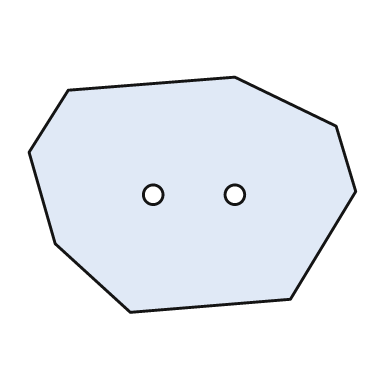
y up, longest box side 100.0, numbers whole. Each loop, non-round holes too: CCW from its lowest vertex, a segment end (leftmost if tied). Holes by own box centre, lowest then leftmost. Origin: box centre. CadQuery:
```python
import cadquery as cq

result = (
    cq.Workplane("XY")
    .moveTo(-19.0, -36.0)
    .lineTo(30.0, -32.0)
    .lineTo(50.0, 1.0)
    .lineTo(44.0, 21.0)
    .lineTo(13.0, 36.0)
    .lineTo(-38.0, 32.0)
    .lineTo(-50.0, 13.0)
    .lineTo(-42.0, -15.0)
    .close()
    .moveTo(-12.0, 0.0)
    .circle(3.0)
    .moveTo(13.0, 0.0)
    .circle(3.0)
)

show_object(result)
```